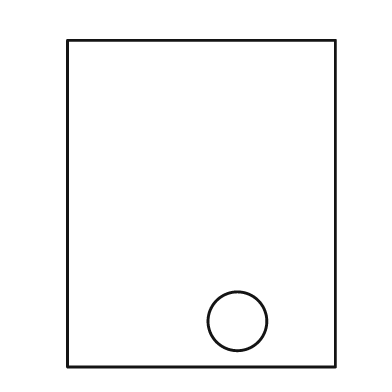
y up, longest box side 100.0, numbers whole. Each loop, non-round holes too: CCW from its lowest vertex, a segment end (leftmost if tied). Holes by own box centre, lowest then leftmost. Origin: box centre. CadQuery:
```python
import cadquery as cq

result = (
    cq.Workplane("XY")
    .moveTo(-41.0, -50.0)
    .lineTo(41.0, -50.0)
    .lineTo(41.0, 50.0)
    .lineTo(-41.0, 50.0)
    .close()
    .moveTo(11.0, -36.0)
    .circle(9.0)
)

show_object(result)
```